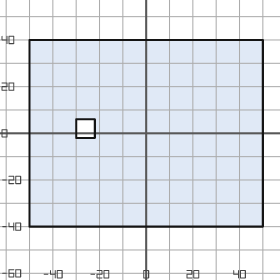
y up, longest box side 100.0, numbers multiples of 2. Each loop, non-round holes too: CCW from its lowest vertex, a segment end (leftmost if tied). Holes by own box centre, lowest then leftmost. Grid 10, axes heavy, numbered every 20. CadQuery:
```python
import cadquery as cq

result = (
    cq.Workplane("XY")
    .moveTo(-50.0, -40.0)
    .lineTo(50.0, -40.0)
    .lineTo(50.0, 40.0)
    .lineTo(-50.0, 40.0)
    .close()
    .moveTo(-30.0, -2.0)
    .lineTo(-22.0, -2.0)
    .lineTo(-22.0, 6.0)
    .lineTo(-30.0, 6.0)
    .close()
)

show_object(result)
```